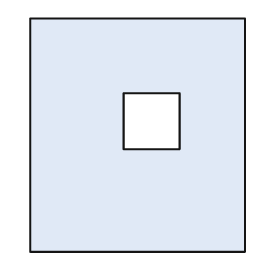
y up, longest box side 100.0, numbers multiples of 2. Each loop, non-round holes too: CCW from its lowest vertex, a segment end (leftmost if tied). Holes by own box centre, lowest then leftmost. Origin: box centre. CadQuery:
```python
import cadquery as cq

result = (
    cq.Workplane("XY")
    .moveTo(-46.0, -50.0)
    .lineTo(46.0, -50.0)
    .lineTo(46.0, 50.0)
    .lineTo(-46.0, 50.0)
    .close()
    .moveTo(-6.0, -6.0)
    .lineTo(18.0, -6.0)
    .lineTo(18.0, 18.0)
    .lineTo(-6.0, 18.0)
    .close()
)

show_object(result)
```